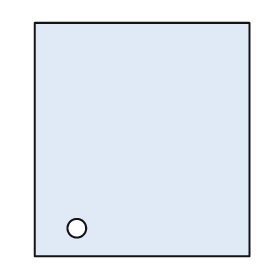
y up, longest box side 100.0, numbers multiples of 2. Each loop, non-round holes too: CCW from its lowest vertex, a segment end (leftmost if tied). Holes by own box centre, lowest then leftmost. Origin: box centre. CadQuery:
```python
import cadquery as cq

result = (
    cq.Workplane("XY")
    .moveTo(-46.0, -50.0)
    .lineTo(46.0, -50.0)
    .lineTo(46.0, 50.0)
    .lineTo(-46.0, 50.0)
    .close()
    .moveTo(-28.0, -38.0)
    .circle(4.0)
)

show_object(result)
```